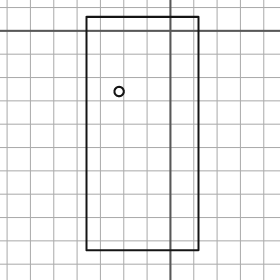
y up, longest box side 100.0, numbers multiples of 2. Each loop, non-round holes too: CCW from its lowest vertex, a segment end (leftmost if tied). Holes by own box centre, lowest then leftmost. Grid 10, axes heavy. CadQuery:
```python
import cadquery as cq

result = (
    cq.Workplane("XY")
    .moveTo(-36.0, -94.0)
    .lineTo(12.0, -94.0)
    .lineTo(12.0, 6.0)
    .lineTo(-36.0, 6.0)
    .close()
    .moveTo(-22.0, -26.0)
    .circle(2.0)
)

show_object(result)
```